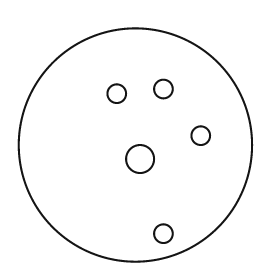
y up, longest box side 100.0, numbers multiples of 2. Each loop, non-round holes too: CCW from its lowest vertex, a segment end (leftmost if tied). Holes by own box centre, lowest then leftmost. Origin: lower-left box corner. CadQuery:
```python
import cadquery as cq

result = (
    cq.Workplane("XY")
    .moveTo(50.0, 50.0)
    .circle(50.0)
    .moveTo(62.0, 12.0)
    .circle(4.0)
    .moveTo(52.0, 44.0)
    .circle(6.0)
    .moveTo(78.0, 54.0)
    .circle(4.0)
    .moveTo(42.0, 72.0)
    .circle(4.0)
    .moveTo(62.0, 74.0)
    .circle(4.0)
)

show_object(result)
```